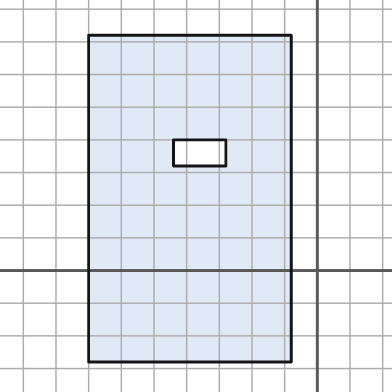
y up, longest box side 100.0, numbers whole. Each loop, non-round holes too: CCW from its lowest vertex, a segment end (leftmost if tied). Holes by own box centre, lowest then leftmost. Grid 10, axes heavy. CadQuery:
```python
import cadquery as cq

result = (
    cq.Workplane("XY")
    .moveTo(-70.0, -28.0)
    .lineTo(-8.0, -28.0)
    .lineTo(-8.0, 72.0)
    .lineTo(-70.0, 72.0)
    .close()
    .moveTo(-44.0, 32.0)
    .lineTo(-28.0, 32.0)
    .lineTo(-28.0, 40.0)
    .lineTo(-44.0, 40.0)
    .close()
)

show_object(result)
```